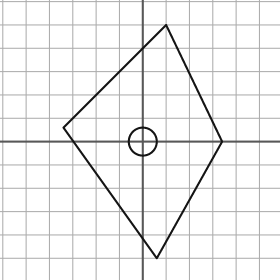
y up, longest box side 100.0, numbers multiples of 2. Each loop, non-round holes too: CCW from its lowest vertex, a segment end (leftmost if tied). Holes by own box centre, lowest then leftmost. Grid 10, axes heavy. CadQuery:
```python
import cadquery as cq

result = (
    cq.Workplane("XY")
    .moveTo(6.0, -50.0)
    .lineTo(34.0, 0.0)
    .lineTo(10.0, 50.0)
    .lineTo(-34.0, 6.0)
    .close()
    .moveTo(0.0, 0.0)
    .circle(6.0)
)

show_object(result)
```